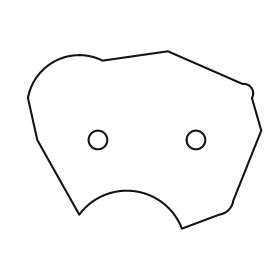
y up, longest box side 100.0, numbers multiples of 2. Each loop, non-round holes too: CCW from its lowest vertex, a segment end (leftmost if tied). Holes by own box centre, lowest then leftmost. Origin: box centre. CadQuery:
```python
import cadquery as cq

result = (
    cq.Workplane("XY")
    .moveTo(16.0, -38.0)
    .lineTo(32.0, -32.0)
    .threePointArc((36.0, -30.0), (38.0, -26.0))
    .lineTo(50.0, 4.0)
    .lineTo(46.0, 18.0)
    .threePointArc((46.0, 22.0), (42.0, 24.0))
    .lineTo(10.0, 38.0)
    .lineTo(-18.0, 34.0)
    .threePointArc((-38.0, 34.0), (-50.0, 18.0))
    .lineTo(-46.0, 0.0)
    .lineTo(-28.0, -32.0)
    .threePointArc((-4.0, -22.0), (16.0, -38.0))
    .close()
    .moveTo(-20.0, 0.0)
    .circle(4.0)
    .moveTo(22.0, 0.0)
    .circle(4.0)
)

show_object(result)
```